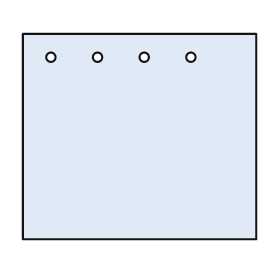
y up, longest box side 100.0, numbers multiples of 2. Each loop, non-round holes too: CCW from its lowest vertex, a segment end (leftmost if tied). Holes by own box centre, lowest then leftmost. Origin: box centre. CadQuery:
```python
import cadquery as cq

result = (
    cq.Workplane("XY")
    .moveTo(-50.0, -44.0)
    .lineTo(50.0, -44.0)
    .lineTo(50.0, 44.0)
    .lineTo(-50.0, 44.0)
    .close()
    .moveTo(-38.0, 34.0)
    .circle(2.0)
    .moveTo(-18.0, 34.0)
    .circle(2.0)
    .moveTo(2.0, 34.0)
    .circle(2.0)
    .moveTo(22.0, 34.0)
    .circle(2.0)
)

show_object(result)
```